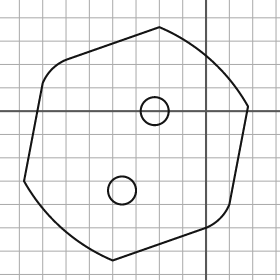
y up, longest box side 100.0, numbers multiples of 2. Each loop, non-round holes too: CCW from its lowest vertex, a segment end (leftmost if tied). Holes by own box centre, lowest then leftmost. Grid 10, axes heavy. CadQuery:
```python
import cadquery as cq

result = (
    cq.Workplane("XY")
    .moveTo(-40.0, -64.0)
    .lineTo(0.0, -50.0)
    .threePointArc((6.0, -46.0), (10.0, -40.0))
    .lineTo(18.0, 2.0)
    .threePointArc((2.0, 22.0), (-20.0, 36.0))
    .lineTo(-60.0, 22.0)
    .threePointArc((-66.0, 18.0), (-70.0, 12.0))
    .lineTo(-78.0, -30.0)
    .threePointArc((-62.0, -50.0), (-40.0, -64.0))
    .close()
    .moveTo(-36.0, -34.0)
    .circle(6.0)
    .moveTo(-22.0, 0.0)
    .circle(6.0)
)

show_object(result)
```